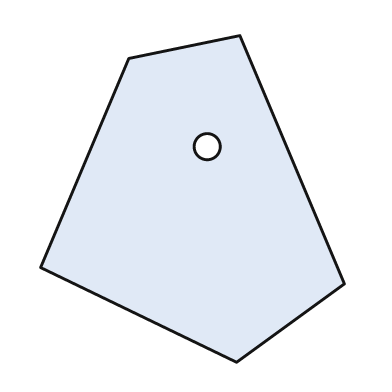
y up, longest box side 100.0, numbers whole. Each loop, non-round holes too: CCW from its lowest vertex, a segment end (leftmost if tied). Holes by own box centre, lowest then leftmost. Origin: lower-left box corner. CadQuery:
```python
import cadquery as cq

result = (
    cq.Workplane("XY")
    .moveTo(60.0, 0.0)
    .lineTo(93.0, 24.0)
    .lineTo(61.0, 100.0)
    .lineTo(27.0, 93.0)
    .lineTo(0.0, 29.0)
    .close()
    .moveTo(51.0, 66.0)
    .circle(4.0)
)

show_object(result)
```